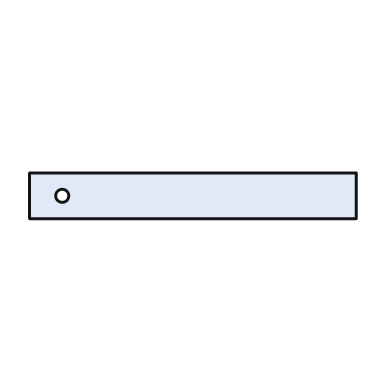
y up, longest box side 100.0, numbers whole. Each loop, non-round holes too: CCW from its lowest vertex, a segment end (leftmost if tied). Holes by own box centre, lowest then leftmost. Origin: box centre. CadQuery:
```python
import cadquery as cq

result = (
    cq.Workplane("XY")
    .moveTo(-50.0, -7.0)
    .lineTo(50.0, -7.0)
    .lineTo(50.0, 7.0)
    .lineTo(-50.0, 7.0)
    .close()
    .moveTo(-40.0, 0.0)
    .circle(2.0)
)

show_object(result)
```